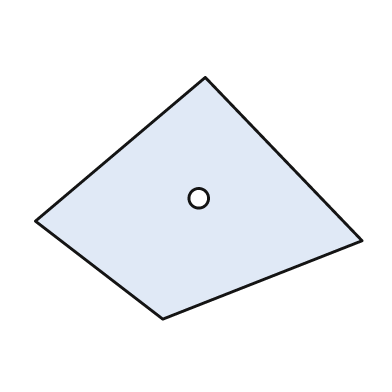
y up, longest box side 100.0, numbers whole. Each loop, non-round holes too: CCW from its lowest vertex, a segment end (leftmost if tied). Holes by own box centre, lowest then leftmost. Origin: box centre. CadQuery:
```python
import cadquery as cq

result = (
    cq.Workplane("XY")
    .moveTo(-11.0, -37.0)
    .lineTo(50.0, -13.0)
    .lineTo(2.0, 37.0)
    .lineTo(-50.0, -7.0)
    .close()
    .moveTo(0.0, 0.0)
    .circle(3.0)
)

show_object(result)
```